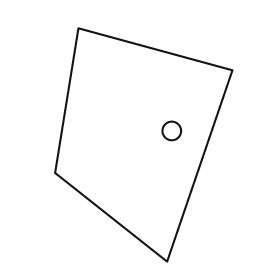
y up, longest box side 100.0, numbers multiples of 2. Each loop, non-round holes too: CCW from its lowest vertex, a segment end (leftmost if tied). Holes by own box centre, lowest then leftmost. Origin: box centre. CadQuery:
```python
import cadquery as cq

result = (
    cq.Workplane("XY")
    .moveTo(10.0, -50.0)
    .lineTo(38.0, 32.0)
    .lineTo(-28.0, 50.0)
    .lineTo(-38.0, -12.0)
    .close()
    .moveTo(12.0, 6.0)
    .circle(4.0)
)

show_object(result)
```